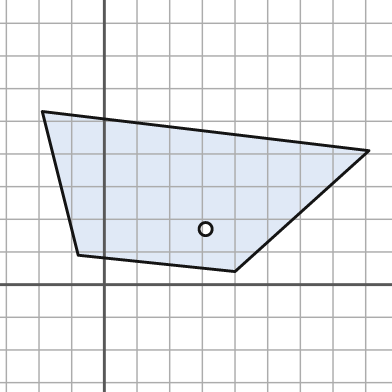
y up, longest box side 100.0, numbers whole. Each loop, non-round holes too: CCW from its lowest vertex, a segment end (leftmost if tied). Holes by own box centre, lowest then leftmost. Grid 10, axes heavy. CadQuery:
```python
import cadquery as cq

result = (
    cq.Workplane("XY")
    .moveTo(40.0, 4.0)
    .lineTo(81.0, 41.0)
    .lineTo(-19.0, 53.0)
    .lineTo(-8.0, 9.0)
    .close()
    .moveTo(31.0, 17.0)
    .circle(2.0)
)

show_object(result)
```